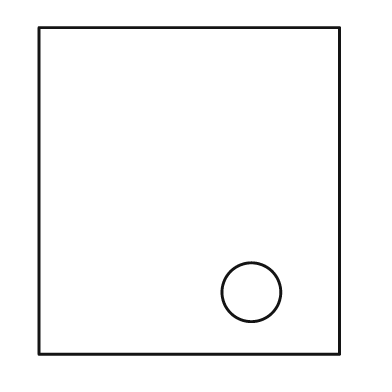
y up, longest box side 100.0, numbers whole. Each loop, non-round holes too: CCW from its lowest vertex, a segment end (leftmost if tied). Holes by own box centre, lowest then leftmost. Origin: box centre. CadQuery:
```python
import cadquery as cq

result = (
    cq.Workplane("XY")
    .moveTo(-46.0, -50.0)
    .lineTo(46.0, -50.0)
    .lineTo(46.0, 50.0)
    .lineTo(-46.0, 50.0)
    .close()
    .moveTo(19.0, -31.0)
    .circle(9.0)
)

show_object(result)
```